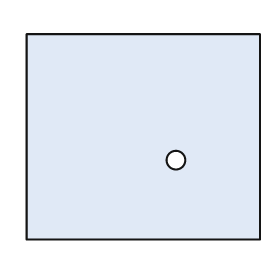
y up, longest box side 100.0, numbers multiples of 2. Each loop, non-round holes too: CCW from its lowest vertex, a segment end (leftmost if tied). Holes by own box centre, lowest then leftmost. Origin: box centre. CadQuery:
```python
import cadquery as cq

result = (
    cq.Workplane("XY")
    .moveTo(-50.0, -44.0)
    .lineTo(50.0, -44.0)
    .lineTo(50.0, 44.0)
    .lineTo(-50.0, 44.0)
    .close()
    .moveTo(14.0, -10.0)
    .circle(4.0)
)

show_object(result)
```